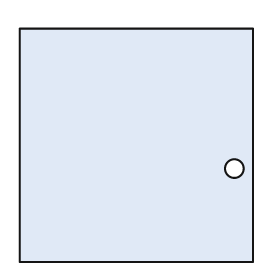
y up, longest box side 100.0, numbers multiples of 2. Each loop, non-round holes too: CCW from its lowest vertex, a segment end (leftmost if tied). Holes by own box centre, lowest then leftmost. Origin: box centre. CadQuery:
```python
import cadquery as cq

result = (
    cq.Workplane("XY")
    .moveTo(-50.0, -50.0)
    .lineTo(50.0, -50.0)
    .lineTo(50.0, 50.0)
    .lineTo(-50.0, 50.0)
    .close()
    .moveTo(42.0, -10.0)
    .circle(4.0)
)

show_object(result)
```